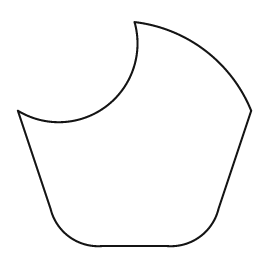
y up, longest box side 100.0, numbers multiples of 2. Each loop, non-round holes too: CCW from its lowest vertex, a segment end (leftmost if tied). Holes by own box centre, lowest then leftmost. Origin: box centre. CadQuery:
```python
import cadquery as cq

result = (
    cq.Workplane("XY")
    .moveTo(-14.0, -48.0)
    .lineTo(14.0, -48.0)
    .threePointArc((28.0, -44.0), (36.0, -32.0))
    .lineTo(50.0, 10.0)
    .threePointArc((30.0, 36.0), (0.0, 48.0))
    .threePointArc((-12.0, 12.0), (-50.0, 10.0))
    .lineTo(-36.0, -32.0)
    .threePointArc((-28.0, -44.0), (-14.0, -48.0))
    .close()
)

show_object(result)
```